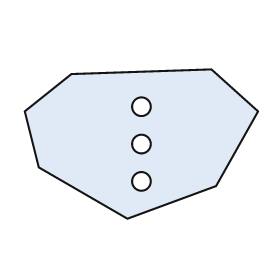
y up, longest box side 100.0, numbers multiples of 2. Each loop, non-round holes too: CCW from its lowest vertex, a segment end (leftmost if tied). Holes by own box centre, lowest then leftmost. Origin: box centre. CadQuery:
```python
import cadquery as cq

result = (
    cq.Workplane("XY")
    .moveTo(-6.0, -32.0)
    .lineTo(32.0, -18.0)
    .lineTo(50.0, 14.0)
    .lineTo(30.0, 32.0)
    .lineTo(-30.0, 30.0)
    .lineTo(-50.0, 14.0)
    .lineTo(-44.0, -10.0)
    .close()
    .moveTo(0.0, -16.0)
    .circle(4.0)
    .moveTo(0.0, 0.0)
    .circle(4.0)
    .moveTo(0.0, 16.0)
    .circle(4.0)
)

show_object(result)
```